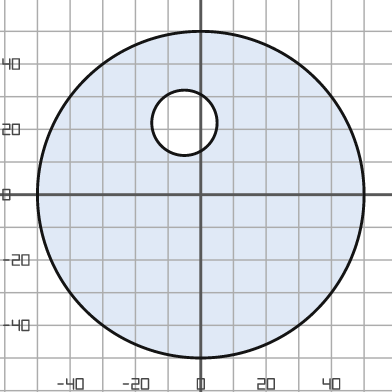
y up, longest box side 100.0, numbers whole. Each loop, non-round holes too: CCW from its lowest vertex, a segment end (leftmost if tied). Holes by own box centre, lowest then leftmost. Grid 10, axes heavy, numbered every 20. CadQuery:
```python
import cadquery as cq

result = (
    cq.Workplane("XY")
    .moveTo(0.0, 0.0)
    .circle(50.0)
    .moveTo(-5.0, 22.0)
    .circle(10.0)
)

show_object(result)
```